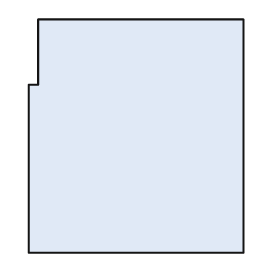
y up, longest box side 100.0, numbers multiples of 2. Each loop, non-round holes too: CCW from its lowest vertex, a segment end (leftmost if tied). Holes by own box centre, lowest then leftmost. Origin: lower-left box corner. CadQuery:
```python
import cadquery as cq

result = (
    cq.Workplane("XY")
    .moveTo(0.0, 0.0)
    .lineTo(92.0, 0.0)
    .lineTo(92.0, 100.0)
    .lineTo(4.0, 100.0)
    .lineTo(4.0, 72.0)
    .lineTo(0.0, 72.0)
    .close()
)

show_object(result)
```